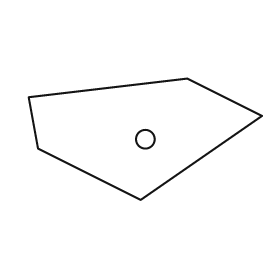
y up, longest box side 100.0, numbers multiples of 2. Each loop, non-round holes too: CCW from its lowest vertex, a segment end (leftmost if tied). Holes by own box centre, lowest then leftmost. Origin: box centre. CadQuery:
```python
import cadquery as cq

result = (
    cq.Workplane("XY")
    .moveTo(-2.0, -26.0)
    .lineTo(50.0, 10.0)
    .lineTo(18.0, 26.0)
    .lineTo(-50.0, 18.0)
    .lineTo(-46.0, -4.0)
    .close()
    .moveTo(0.0, 0.0)
    .circle(4.0)
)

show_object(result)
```